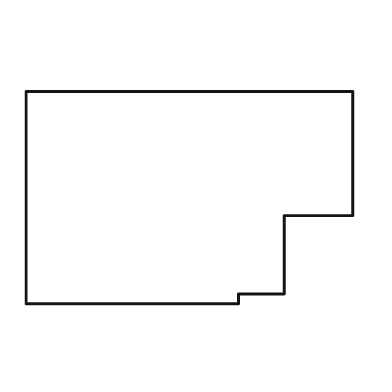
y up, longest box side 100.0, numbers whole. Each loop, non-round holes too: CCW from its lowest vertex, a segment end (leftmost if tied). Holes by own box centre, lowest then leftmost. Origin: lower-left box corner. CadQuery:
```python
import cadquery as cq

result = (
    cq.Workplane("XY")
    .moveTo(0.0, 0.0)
    .lineTo(65.0, 0.0)
    .lineTo(65.0, 3.0)
    .lineTo(79.0, 3.0)
    .lineTo(79.0, 27.0)
    .lineTo(100.0, 27.0)
    .lineTo(100.0, 65.0)
    .lineTo(0.0, 65.0)
    .close()
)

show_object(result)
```